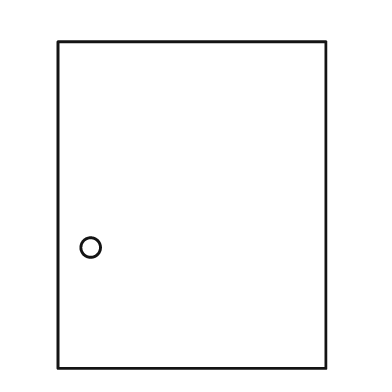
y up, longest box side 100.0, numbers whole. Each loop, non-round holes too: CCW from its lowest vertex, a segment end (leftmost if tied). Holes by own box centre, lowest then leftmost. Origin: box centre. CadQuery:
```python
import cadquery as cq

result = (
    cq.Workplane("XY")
    .moveTo(-41.0, -50.0)
    .lineTo(41.0, -50.0)
    .lineTo(41.0, 50.0)
    .lineTo(-41.0, 50.0)
    .close()
    .moveTo(-31.0, -13.0)
    .circle(3.0)
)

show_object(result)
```